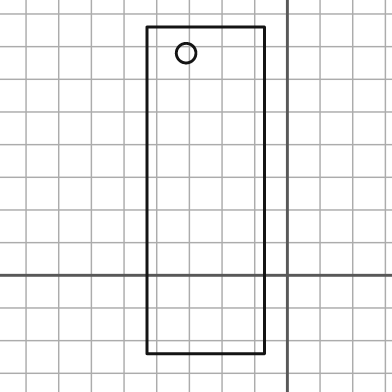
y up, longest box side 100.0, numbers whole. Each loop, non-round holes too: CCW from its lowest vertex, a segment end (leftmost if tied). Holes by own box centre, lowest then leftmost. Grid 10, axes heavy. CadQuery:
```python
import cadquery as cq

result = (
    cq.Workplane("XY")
    .moveTo(-43.0, -24.0)
    .lineTo(-7.0, -24.0)
    .lineTo(-7.0, 76.0)
    .lineTo(-43.0, 76.0)
    .close()
    .moveTo(-31.0, 68.0)
    .circle(3.0)
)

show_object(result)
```